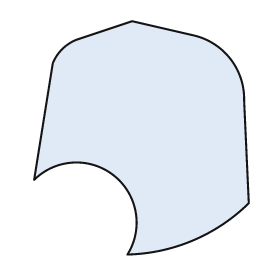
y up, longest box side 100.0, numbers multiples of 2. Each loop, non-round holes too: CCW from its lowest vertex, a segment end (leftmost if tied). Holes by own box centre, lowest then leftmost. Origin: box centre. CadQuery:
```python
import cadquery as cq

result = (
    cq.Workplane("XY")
    .moveTo(-6.0, -50.0)
    .threePointArc((22.0, -44.0), (46.0, -28.0))
    .lineTo(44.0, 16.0)
    .threePointArc((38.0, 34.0), (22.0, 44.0))
    .lineTo(-4.0, 50.0)
    .lineTo(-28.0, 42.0)
    .threePointArc((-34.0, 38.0), (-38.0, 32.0))
    .lineTo(-46.0, -18.0)
    .threePointArc((-12.0, -16.0), (-6.0, -50.0))
    .close()
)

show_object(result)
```